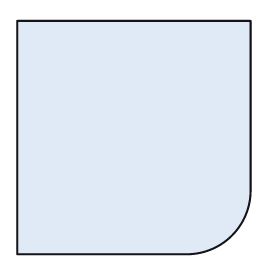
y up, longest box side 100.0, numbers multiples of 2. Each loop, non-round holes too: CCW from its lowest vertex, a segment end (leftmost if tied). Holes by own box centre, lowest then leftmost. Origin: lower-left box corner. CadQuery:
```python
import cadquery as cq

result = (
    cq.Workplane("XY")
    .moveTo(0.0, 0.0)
    .lineTo(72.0, 0.0)
    .threePointArc((92.0, 8.0), (100.0, 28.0))
    .lineTo(100.0, 100.0)
    .lineTo(0.0, 100.0)
    .close()
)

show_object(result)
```